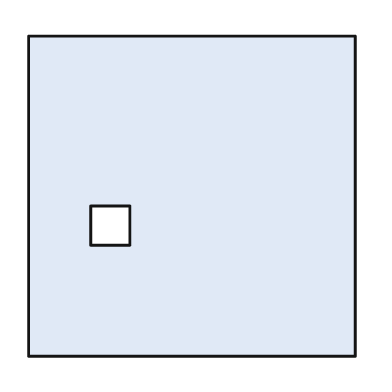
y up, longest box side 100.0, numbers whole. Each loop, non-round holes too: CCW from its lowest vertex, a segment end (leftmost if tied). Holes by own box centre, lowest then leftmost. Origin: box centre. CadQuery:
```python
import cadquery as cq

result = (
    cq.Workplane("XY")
    .moveTo(-50.0, -49.0)
    .lineTo(50.0, -49.0)
    .lineTo(50.0, 49.0)
    .lineTo(-50.0, 49.0)
    .close()
    .moveTo(-31.0, -15.0)
    .lineTo(-19.0, -15.0)
    .lineTo(-19.0, -3.0)
    .lineTo(-31.0, -3.0)
    .close()
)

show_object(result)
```